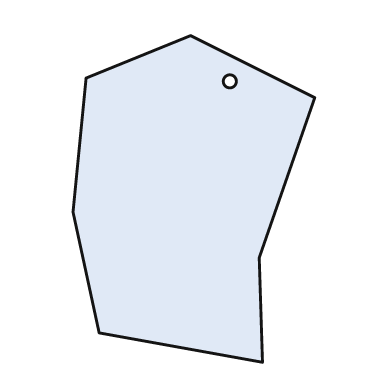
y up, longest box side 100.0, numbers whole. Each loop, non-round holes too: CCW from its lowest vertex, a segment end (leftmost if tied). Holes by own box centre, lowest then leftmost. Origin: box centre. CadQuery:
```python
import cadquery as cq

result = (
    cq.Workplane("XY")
    .moveTo(21.0, -50.0)
    .lineTo(20.0, -18.0)
    .lineTo(37.0, 31.0)
    .lineTo(-1.0, 50.0)
    .lineTo(-33.0, 37.0)
    .lineTo(-37.0, -4.0)
    .lineTo(-29.0, -41.0)
    .close()
    .moveTo(11.0, 36.0)
    .circle(2.0)
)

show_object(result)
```